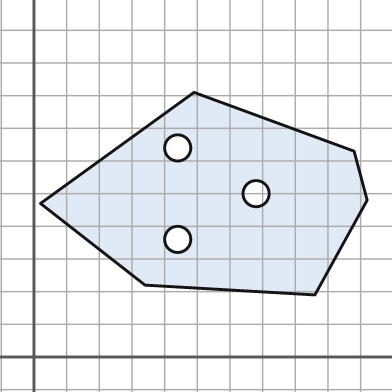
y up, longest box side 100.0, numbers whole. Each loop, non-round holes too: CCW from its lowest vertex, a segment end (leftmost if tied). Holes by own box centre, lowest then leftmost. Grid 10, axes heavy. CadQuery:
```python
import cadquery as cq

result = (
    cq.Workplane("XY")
    .moveTo(86.0, 19.0)
    .lineTo(102.0, 48.0)
    .lineTo(98.0, 63.0)
    .lineTo(49.0, 81.0)
    .lineTo(2.0, 47.0)
    .lineTo(34.0, 22.0)
    .close()
    .moveTo(44.0, 36.0)
    .circle(4.0)
    .moveTo(68.0, 50.0)
    .circle(4.0)
    .moveTo(44.0, 64.0)
    .circle(4.0)
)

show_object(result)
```